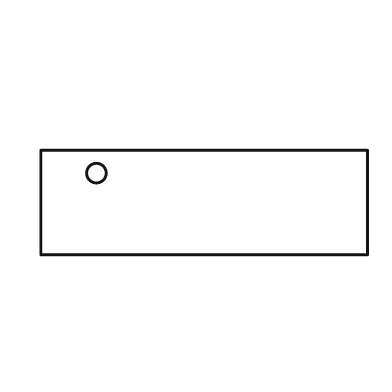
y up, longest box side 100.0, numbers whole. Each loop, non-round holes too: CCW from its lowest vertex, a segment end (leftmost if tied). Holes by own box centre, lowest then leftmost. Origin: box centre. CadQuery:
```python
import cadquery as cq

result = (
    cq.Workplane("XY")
    .moveTo(-50.0, -16.0)
    .lineTo(50.0, -16.0)
    .lineTo(50.0, 16.0)
    .lineTo(-50.0, 16.0)
    .close()
    .moveTo(-33.0, 9.0)
    .circle(3.0)
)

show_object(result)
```